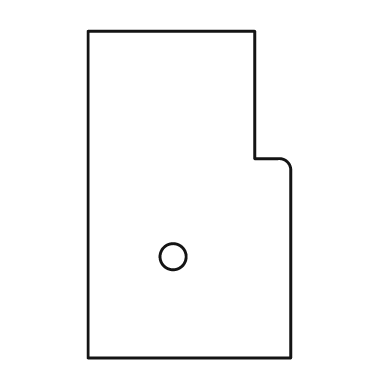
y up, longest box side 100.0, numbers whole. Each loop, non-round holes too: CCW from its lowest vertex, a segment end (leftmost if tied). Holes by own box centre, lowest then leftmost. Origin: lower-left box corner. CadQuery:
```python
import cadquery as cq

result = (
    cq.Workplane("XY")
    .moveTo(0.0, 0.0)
    .lineTo(62.0, 0.0)
    .lineTo(62.0, 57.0)
    .threePointArc((61.0, 60.0), (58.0, 61.0))
    .lineTo(51.0, 61.0)
    .lineTo(51.0, 100.0)
    .lineTo(0.0, 100.0)
    .close()
    .moveTo(26.0, 31.0)
    .circle(4.0)
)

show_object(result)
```